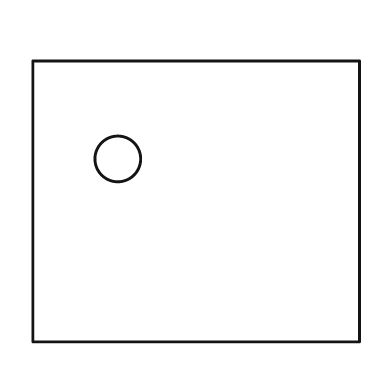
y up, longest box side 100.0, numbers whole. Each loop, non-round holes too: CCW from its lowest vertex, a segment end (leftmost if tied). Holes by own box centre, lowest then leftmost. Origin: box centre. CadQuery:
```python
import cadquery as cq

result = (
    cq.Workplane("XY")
    .moveTo(-50.0, -43.0)
    .lineTo(50.0, -43.0)
    .lineTo(50.0, 43.0)
    .lineTo(-50.0, 43.0)
    .close()
    .moveTo(-24.0, 13.0)
    .circle(7.0)
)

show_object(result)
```